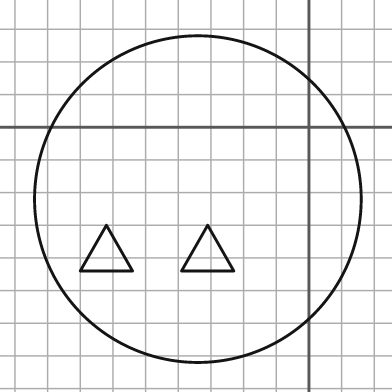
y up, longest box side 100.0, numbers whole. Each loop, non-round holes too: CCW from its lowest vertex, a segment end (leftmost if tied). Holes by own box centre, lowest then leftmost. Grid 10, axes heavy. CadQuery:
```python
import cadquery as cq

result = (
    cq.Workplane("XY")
    .moveTo(-34.0, -22.0)
    .circle(50.0)
    .moveTo(-70.0, -44.0)
    .lineTo(-54.0, -44.0)
    .lineTo(-62.0, -30.0)
    .close()
    .moveTo(-39.0, -44.0)
    .lineTo(-23.0, -44.0)
    .lineTo(-31.0, -30.0)
    .close()
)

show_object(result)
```